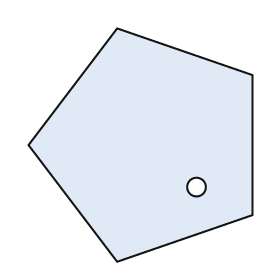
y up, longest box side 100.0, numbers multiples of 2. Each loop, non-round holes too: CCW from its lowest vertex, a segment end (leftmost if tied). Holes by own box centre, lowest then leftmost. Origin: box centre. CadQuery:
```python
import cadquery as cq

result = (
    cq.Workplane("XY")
    .moveTo(-10.0, -50.0)
    .lineTo(48.0, -30.0)
    .lineTo(48.0, 30.0)
    .lineTo(-10.0, 50.0)
    .lineTo(-48.0, 0.0)
    .close()
    .moveTo(24.0, -18.0)
    .circle(4.0)
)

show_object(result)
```